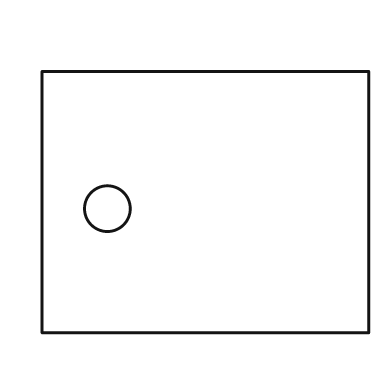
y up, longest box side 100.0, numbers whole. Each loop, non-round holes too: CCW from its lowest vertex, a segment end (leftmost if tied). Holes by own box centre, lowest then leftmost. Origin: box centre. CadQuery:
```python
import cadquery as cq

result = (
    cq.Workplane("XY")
    .moveTo(-50.0, -40.0)
    .lineTo(50.0, -40.0)
    .lineTo(50.0, 40.0)
    .lineTo(-50.0, 40.0)
    .close()
    .moveTo(-30.0, -2.0)
    .circle(7.0)
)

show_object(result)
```